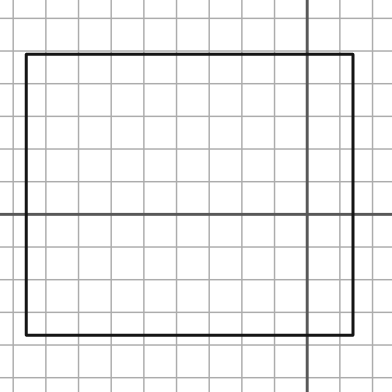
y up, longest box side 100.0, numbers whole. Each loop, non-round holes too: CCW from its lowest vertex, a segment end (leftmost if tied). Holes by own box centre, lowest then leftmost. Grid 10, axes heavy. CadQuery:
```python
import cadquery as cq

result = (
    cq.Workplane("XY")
    .moveTo(-86.0, -37.0)
    .lineTo(14.0, -37.0)
    .lineTo(14.0, 49.0)
    .lineTo(-86.0, 49.0)
    .close()
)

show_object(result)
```